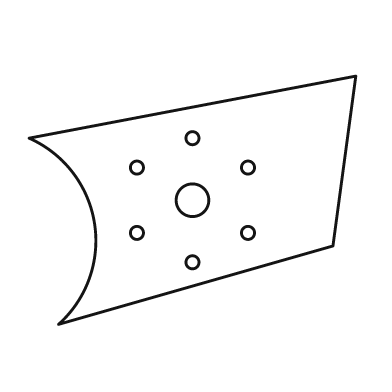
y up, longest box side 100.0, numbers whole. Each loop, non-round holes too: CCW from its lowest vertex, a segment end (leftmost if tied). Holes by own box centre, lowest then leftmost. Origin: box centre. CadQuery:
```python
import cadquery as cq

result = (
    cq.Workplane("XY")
    .moveTo(-41.0, -38.0)
    .lineTo(43.0, -14.0)
    .lineTo(50.0, 38.0)
    .lineTo(-50.0, 19.0)
    .threePointArc((-30.0, -7.0), (-41.0, -38.0))
    .close()
    .moveTo(0.0, -19.0)
    .circle(2.0)
    .moveTo(-17.0, -10.0)
    .circle(2.0)
    .moveTo(17.0, -10.0)
    .circle(2.0)
    .moveTo(0.0, 0.0)
    .circle(5.0)
    .moveTo(-17.0, 10.0)
    .circle(2.0)
    .moveTo(17.0, 10.0)
    .circle(2.0)
    .moveTo(0.0, 19.0)
    .circle(2.0)
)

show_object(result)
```